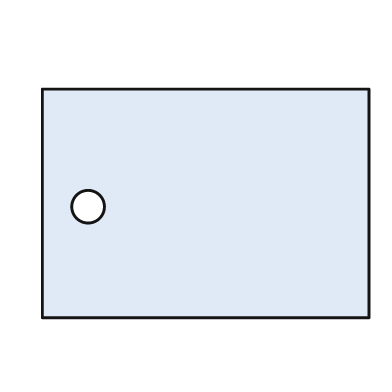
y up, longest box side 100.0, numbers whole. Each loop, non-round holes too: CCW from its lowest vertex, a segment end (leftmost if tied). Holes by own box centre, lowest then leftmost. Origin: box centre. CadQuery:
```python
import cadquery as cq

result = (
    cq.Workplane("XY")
    .moveTo(-50.0, -35.0)
    .lineTo(50.0, -35.0)
    .lineTo(50.0, 35.0)
    .lineTo(-50.0, 35.0)
    .close()
    .moveTo(-36.0, -1.0)
    .circle(5.0)
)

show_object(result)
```